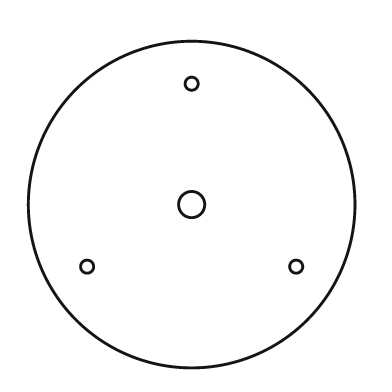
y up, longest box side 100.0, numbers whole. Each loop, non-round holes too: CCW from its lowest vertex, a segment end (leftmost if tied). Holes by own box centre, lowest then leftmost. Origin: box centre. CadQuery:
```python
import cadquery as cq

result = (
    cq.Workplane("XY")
    .moveTo(0.0, 0.0)
    .circle(50.0)
    .moveTo(-32.0, -19.0)
    .circle(2.0)
    .moveTo(32.0, -19.0)
    .circle(2.0)
    .moveTo(0.0, 0.0)
    .circle(4.0)
    .moveTo(0.0, 37.0)
    .circle(2.0)
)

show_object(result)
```